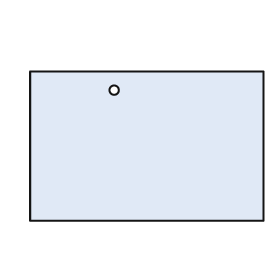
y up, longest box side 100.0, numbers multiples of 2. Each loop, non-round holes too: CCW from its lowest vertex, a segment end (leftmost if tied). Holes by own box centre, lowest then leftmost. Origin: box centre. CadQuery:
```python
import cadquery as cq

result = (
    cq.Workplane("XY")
    .moveTo(-50.0, -32.0)
    .lineTo(50.0, -32.0)
    .lineTo(50.0, 32.0)
    .lineTo(-50.0, 32.0)
    .close()
    .moveTo(-14.0, 24.0)
    .circle(2.0)
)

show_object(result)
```